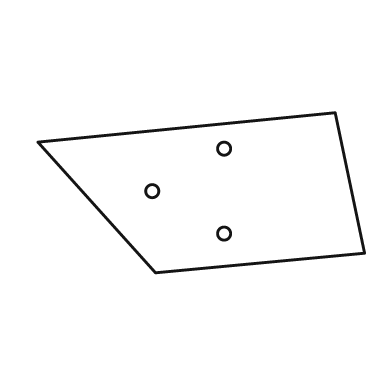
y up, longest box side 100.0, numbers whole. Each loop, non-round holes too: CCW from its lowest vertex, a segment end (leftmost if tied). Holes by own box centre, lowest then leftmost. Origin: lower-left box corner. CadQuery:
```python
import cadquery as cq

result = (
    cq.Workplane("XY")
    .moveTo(36.0, 0.0)
    .lineTo(100.0, 6.0)
    .lineTo(91.0, 49.0)
    .lineTo(0.0, 40.0)
    .close()
    .moveTo(57.0, 12.0)
    .circle(2.0)
    .moveTo(35.0, 25.0)
    .circle(2.0)
    .moveTo(57.0, 38.0)
    .circle(2.0)
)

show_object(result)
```